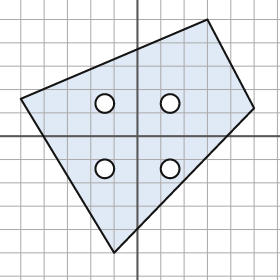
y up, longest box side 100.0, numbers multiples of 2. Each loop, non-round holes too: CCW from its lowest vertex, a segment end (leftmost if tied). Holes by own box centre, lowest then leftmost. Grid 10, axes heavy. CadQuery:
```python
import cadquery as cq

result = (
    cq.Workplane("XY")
    .moveTo(-10.0, -50.0)
    .lineTo(50.0, 12.0)
    .lineTo(30.0, 50.0)
    .lineTo(-50.0, 16.0)
    .close()
    .moveTo(-14.0, -14.0)
    .circle(4.0)
    .moveTo(14.0, -14.0)
    .circle(4.0)
    .moveTo(-14.0, 14.0)
    .circle(4.0)
    .moveTo(14.0, 14.0)
    .circle(4.0)
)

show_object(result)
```